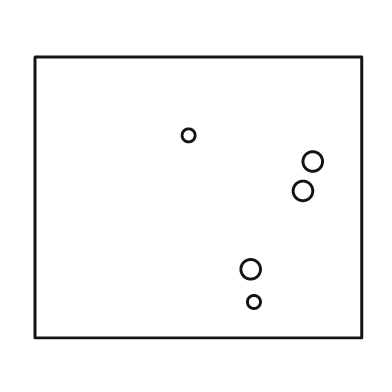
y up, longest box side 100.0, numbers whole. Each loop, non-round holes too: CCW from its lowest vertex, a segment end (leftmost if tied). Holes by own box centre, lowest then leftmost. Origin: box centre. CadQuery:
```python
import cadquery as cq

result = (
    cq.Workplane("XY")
    .moveTo(-50.0, -43.0)
    .lineTo(50.0, -43.0)
    .lineTo(50.0, 43.0)
    .lineTo(-50.0, 43.0)
    .close()
    .moveTo(17.0, -32.0)
    .circle(2.0)
    .moveTo(16.0, -22.0)
    .circle(3.0)
    .moveTo(32.0, 2.0)
    .circle(3.0)
    .moveTo(35.0, 11.0)
    .circle(3.0)
    .moveTo(-3.0, 19.0)
    .circle(2.0)
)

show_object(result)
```